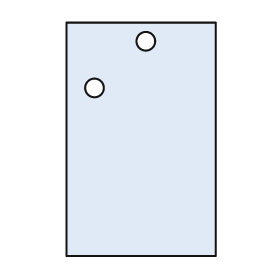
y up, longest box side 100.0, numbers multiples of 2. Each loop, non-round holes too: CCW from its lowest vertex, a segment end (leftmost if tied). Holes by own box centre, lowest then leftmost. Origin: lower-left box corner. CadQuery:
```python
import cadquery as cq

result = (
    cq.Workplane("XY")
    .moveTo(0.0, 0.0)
    .lineTo(64.0, 0.0)
    .lineTo(64.0, 100.0)
    .lineTo(0.0, 100.0)
    .close()
    .moveTo(12.0, 72.0)
    .circle(4.0)
    .moveTo(34.0, 92.0)
    .circle(4.0)
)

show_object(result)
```